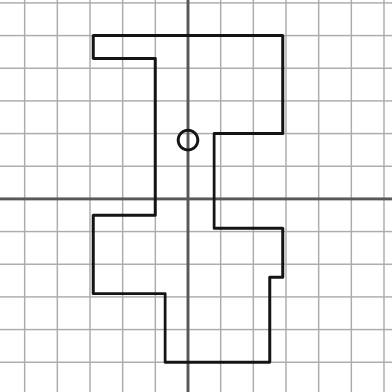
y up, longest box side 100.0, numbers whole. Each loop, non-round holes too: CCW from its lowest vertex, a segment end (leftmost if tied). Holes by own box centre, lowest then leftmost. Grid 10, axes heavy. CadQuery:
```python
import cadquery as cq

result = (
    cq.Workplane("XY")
    .moveTo(-7.0, -50.0)
    .lineTo(25.0, -50.0)
    .lineTo(25.0, -24.0)
    .lineTo(29.0, -24.0)
    .lineTo(29.0, -9.0)
    .lineTo(8.0, -9.0)
    .lineTo(8.0, 20.0)
    .lineTo(29.0, 20.0)
    .lineTo(29.0, 50.0)
    .lineTo(-29.0, 50.0)
    .lineTo(-29.0, 43.0)
    .lineTo(-10.0, 43.0)
    .lineTo(-10.0, -5.0)
    .lineTo(-29.0, -5.0)
    .lineTo(-29.0, -29.0)
    .lineTo(-7.0, -29.0)
    .close()
    .moveTo(0.0, 18.0)
    .circle(3.0)
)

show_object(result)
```